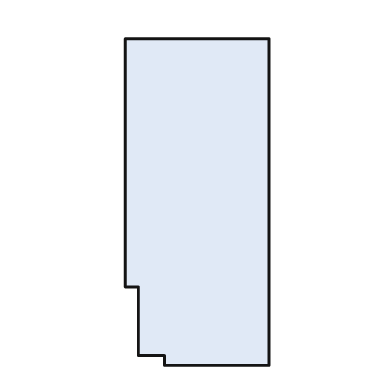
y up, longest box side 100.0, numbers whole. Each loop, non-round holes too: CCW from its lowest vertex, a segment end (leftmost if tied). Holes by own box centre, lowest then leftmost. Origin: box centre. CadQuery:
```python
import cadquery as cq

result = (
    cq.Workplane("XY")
    .moveTo(-10.0, -50.0)
    .lineTo(22.0, -50.0)
    .lineTo(22.0, 50.0)
    .lineTo(-22.0, 50.0)
    .lineTo(-22.0, -26.0)
    .lineTo(-18.0, -26.0)
    .lineTo(-18.0, -47.0)
    .lineTo(-10.0, -47.0)
    .close()
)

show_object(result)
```